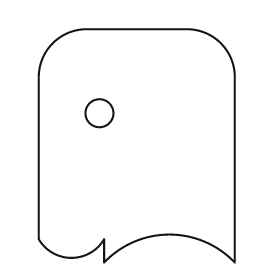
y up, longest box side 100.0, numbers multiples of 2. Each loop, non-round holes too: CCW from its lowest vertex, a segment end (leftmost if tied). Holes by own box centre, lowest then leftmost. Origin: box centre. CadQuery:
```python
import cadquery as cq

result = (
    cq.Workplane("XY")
    .moveTo(-14.0, -50.0)
    .threePointArc((14.0, -38.0), (42.0, -50.0))
    .lineTo(42.0, 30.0)
    .threePointArc((36.0, 44.0), (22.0, 50.0))
    .lineTo(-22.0, 50.0)
    .threePointArc((-36.0, 44.0), (-42.0, 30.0))
    .lineTo(-42.0, -40.0)
    .threePointArc((-28.0, -48.0), (-14.0, -40.0))
    .close()
    .moveTo(-16.0, 14.0)
    .circle(6.0)
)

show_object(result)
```